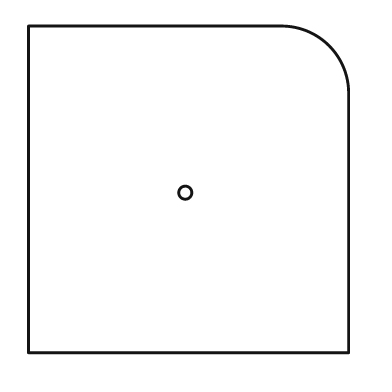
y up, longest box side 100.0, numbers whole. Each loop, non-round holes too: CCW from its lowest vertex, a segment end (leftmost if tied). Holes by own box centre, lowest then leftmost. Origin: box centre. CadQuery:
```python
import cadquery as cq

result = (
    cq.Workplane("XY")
    .moveTo(-49.0, -50.0)
    .lineTo(49.0, -50.0)
    .lineTo(49.0, 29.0)
    .threePointArc((43.0, 44.0), (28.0, 50.0))
    .lineTo(-49.0, 50.0)
    .close()
    .moveTo(-1.0, -1.0)
    .circle(2.0)
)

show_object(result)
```